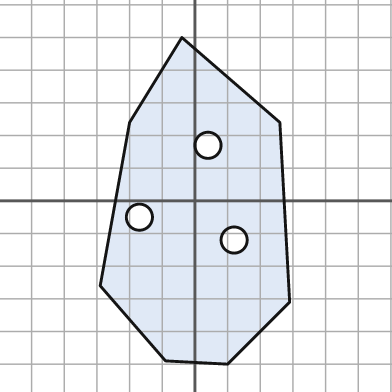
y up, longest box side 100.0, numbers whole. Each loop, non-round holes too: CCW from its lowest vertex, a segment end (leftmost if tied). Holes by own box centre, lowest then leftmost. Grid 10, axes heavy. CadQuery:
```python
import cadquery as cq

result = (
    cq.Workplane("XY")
    .moveTo(10.0, -50.0)
    .lineTo(29.0, -31.0)
    .lineTo(26.0, 24.0)
    .lineTo(-4.0, 50.0)
    .lineTo(-20.0, 24.0)
    .lineTo(-29.0, -26.0)
    .lineTo(-9.0, -49.0)
    .close()
    .moveTo(12.0, -12.0)
    .circle(4.0)
    .moveTo(-17.0, -5.0)
    .circle(4.0)
    .moveTo(4.0, 17.0)
    .circle(4.0)
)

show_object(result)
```